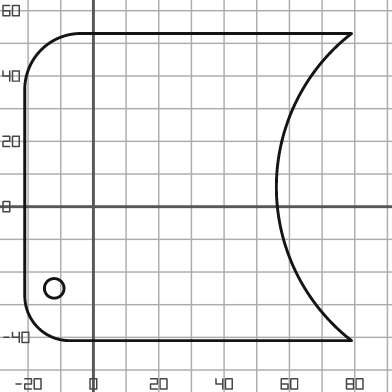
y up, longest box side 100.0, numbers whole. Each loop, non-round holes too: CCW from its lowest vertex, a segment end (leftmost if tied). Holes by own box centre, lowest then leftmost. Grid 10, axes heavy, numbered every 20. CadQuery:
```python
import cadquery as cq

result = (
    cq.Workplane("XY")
    .moveTo(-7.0, -41.0)
    .lineTo(79.0, -41.0)
    .threePointArc((56.0, 6.0), (79.0, 53.0))
    .lineTo(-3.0, 53.0)
    .threePointArc((-16.0, 48.0), (-21.0, 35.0))
    .lineTo(-21.0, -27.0)
    .threePointArc((-17.0, -37.0), (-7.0, -41.0))
    .close()
    .moveTo(-12.0, -25.0)
    .circle(3.0)
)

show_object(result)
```